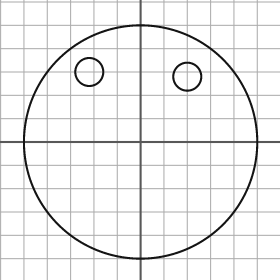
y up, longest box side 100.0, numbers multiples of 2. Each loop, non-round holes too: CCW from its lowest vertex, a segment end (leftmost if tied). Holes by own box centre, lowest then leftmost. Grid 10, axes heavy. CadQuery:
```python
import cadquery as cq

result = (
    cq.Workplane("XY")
    .moveTo(0.0, 0.0)
    .circle(50.0)
    .moveTo(20.0, 28.0)
    .circle(6.0)
    .moveTo(-22.0, 30.0)
    .circle(6.0)
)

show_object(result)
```